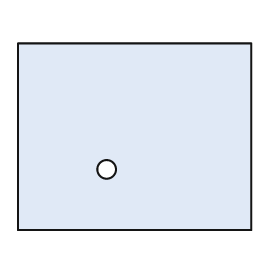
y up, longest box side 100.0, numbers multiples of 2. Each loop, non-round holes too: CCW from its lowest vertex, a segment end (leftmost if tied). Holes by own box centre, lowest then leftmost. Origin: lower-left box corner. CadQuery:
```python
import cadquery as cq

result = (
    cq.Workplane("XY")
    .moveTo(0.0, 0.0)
    .lineTo(100.0, 0.0)
    .lineTo(100.0, 80.0)
    .lineTo(0.0, 80.0)
    .close()
    .moveTo(38.0, 26.0)
    .circle(4.0)
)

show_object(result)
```